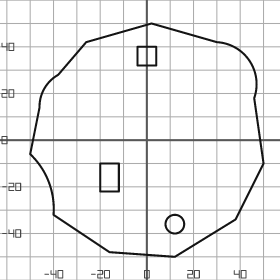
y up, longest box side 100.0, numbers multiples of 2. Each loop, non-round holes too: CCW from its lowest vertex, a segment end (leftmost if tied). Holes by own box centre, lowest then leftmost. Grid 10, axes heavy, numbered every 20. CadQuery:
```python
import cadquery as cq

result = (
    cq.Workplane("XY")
    .moveTo(12.0, -50.0)
    .lineTo(38.0, -34.0)
    .lineTo(50.0, -10.0)
    .lineTo(46.0, 18.0)
    .threePointArc((44.0, 34.0), (30.0, 42.0))
    .lineTo(2.0, 50.0)
    .lineTo(-26.0, 42.0)
    .lineTo(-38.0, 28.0)
    .threePointArc((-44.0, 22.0), (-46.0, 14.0))
    .lineTo(-50.0, -6.0)
    .threePointArc((-42.0, -18.0), (-40.0, -32.0))
    .lineTo(-16.0, -48.0)
    .close()
    .moveTo(12.0, -36.0)
    .circle(4.0)
    .moveTo(-20.0, -22.0)
    .lineTo(-12.0, -22.0)
    .lineTo(-12.0, -10.0)
    .lineTo(-20.0, -10.0)
    .close()
    .moveTo(-4.0, 32.0)
    .lineTo(4.0, 32.0)
    .lineTo(4.0, 40.0)
    .lineTo(-4.0, 40.0)
    .close()
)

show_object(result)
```